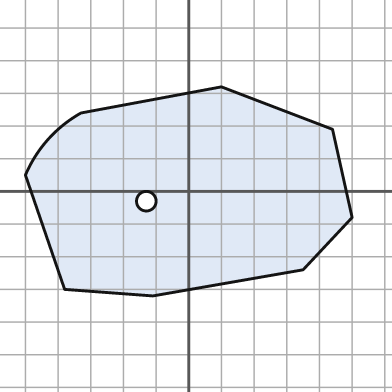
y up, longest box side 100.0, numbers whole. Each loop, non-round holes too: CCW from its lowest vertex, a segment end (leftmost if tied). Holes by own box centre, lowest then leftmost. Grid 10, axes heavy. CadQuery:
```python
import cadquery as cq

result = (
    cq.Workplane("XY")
    .moveTo(-11.0, -32.0)
    .lineTo(35.0, -24.0)
    .lineTo(50.0, -8.0)
    .lineTo(44.0, 19.0)
    .lineTo(10.0, 32.0)
    .lineTo(-33.0, 24.0)
    .threePointArc((-43.0, 16.0), (-50.0, 5.0))
    .lineTo(-38.0, -30.0)
    .close()
    .moveTo(-13.0, -3.0)
    .circle(3.0)
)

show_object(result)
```